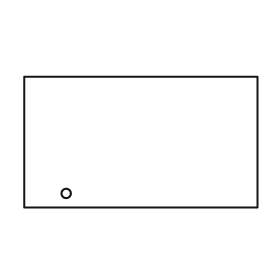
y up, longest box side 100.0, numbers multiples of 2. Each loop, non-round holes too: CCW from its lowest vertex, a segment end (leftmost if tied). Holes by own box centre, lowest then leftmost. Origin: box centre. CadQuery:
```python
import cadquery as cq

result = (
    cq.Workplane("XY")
    .moveTo(-50.0, -28.0)
    .lineTo(50.0, -28.0)
    .lineTo(50.0, 28.0)
    .lineTo(-50.0, 28.0)
    .close()
    .moveTo(-32.0, -22.0)
    .circle(2.0)
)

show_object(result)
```